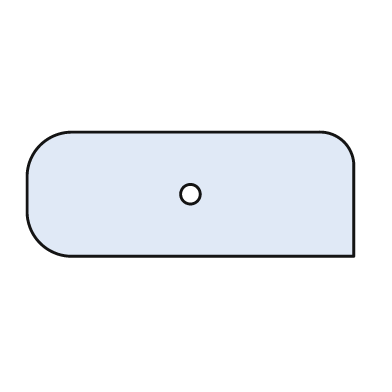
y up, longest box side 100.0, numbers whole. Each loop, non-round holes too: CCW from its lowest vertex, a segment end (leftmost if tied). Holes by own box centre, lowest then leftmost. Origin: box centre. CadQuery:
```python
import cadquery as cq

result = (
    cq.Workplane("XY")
    .moveTo(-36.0, -19.0)
    .lineTo(50.0, -19.0)
    .lineTo(50.0, 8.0)
    .threePointArc((47.0, 16.0), (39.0, 19.0))
    .lineTo(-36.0, 19.0)
    .threePointArc((-46.0, 15.0), (-50.0, 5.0))
    .lineTo(-50.0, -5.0)
    .threePointArc((-46.0, -15.0), (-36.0, -19.0))
    .close()
    .moveTo(0.0, 0.0)
    .circle(3.0)
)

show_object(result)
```